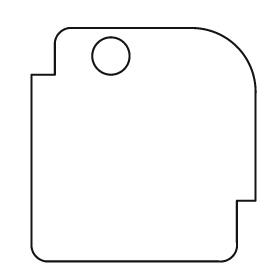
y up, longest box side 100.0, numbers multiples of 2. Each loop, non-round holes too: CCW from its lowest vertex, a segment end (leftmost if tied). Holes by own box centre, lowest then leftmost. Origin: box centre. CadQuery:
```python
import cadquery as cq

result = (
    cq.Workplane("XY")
    .moveTo(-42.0, -50.0)
    .lineTo(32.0, -50.0)
    .threePointArc((38.0, -48.0), (40.0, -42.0))
    .lineTo(40.0, -24.0)
    .lineTo(48.0, -24.0)
    .lineTo(48.0, 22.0)
    .threePointArc((40.0, 42.0), (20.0, 50.0))
    .lineTo(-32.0, 50.0)
    .threePointArc((-36.0, 48.0), (-38.0, 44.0))
    .lineTo(-38.0, 30.0)
    .lineTo(-48.0, 30.0)
    .lineTo(-48.0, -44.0)
    .threePointArc((-46.0, -48.0), (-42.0, -50.0))
    .close()
    .moveTo(-14.0, 38.0)
    .circle(8.0)
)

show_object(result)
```